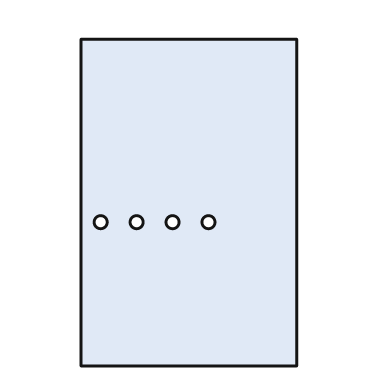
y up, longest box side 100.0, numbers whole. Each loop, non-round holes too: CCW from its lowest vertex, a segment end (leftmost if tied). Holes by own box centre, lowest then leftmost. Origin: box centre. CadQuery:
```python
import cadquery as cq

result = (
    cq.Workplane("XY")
    .moveTo(-33.0, -50.0)
    .lineTo(33.0, -50.0)
    .lineTo(33.0, 50.0)
    .lineTo(-33.0, 50.0)
    .close()
    .moveTo(-27.0, -6.0)
    .circle(2.0)
    .moveTo(-16.0, -6.0)
    .circle(2.0)
    .moveTo(-5.0, -6.0)
    .circle(2.0)
    .moveTo(6.0, -6.0)
    .circle(2.0)
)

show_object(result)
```